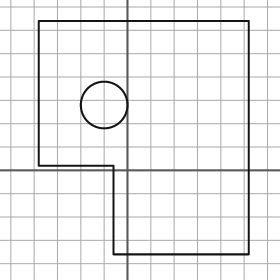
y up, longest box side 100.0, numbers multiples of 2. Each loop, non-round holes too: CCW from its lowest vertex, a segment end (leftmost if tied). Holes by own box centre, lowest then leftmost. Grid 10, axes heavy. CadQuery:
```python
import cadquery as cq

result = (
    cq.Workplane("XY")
    .moveTo(-6.0, -36.0)
    .lineTo(52.0, -36.0)
    .lineTo(52.0, 64.0)
    .lineTo(-38.0, 64.0)
    .lineTo(-38.0, 2.0)
    .lineTo(-6.0, 2.0)
    .close()
    .moveTo(-10.0, 28.0)
    .circle(10.0)
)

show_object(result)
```